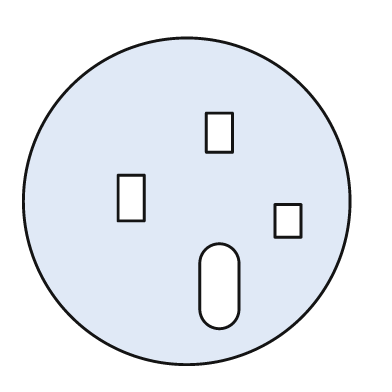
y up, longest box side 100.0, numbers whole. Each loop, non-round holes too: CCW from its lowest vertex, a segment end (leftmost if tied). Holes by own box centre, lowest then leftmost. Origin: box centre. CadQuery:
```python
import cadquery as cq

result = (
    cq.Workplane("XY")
    .moveTo(0.0, 0.0)
    .circle(50.0)
    .moveTo(4.0, -33.0)
    .threePointArc((10.0, -39.0), (16.0, -33.0))
    .lineTo(16.0, -19.0)
    .threePointArc((10.0, -13.0), (4.0, -19.0))
    .close()
    .moveTo(27.0, -11.0)
    .lineTo(35.0, -11.0)
    .lineTo(35.0, -1.0)
    .lineTo(27.0, -1.0)
    .close()
    .moveTo(-21.0, -6.0)
    .lineTo(-13.0, -6.0)
    .lineTo(-13.0, 8.0)
    .lineTo(-21.0, 8.0)
    .close()
    .moveTo(6.0, 15.0)
    .lineTo(14.0, 15.0)
    .lineTo(14.0, 27.0)
    .lineTo(6.0, 27.0)
    .close()
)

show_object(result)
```